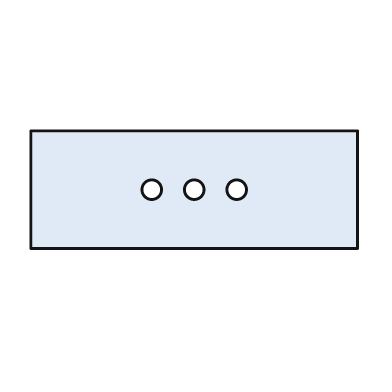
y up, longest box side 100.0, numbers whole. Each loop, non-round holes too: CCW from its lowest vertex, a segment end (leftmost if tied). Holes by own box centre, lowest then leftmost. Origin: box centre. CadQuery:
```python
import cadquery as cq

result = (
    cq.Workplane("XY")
    .moveTo(-50.0, -18.0)
    .lineTo(50.0, -18.0)
    .lineTo(50.0, 18.0)
    .lineTo(-50.0, 18.0)
    .close()
    .moveTo(-13.0, 0.0)
    .circle(3.0)
    .moveTo(0.0, 0.0)
    .circle(3.0)
    .moveTo(13.0, 0.0)
    .circle(3.0)
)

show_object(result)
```